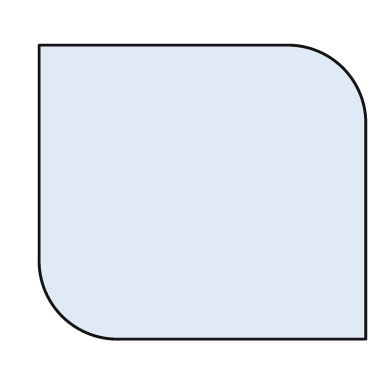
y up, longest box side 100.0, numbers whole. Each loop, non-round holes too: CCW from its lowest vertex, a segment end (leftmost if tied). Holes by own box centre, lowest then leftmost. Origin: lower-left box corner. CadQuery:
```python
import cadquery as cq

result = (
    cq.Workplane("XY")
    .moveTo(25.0, 0.0)
    .lineTo(100.0, 0.0)
    .lineTo(100.0, 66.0)
    .threePointArc((93.0, 83.0), (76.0, 90.0))
    .lineTo(0.0, 90.0)
    .lineTo(0.0, 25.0)
    .threePointArc((7.0, 7.0), (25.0, 0.0))
    .close()
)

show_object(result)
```